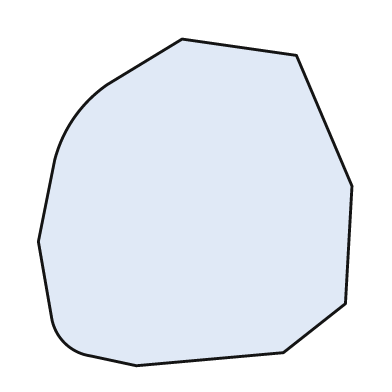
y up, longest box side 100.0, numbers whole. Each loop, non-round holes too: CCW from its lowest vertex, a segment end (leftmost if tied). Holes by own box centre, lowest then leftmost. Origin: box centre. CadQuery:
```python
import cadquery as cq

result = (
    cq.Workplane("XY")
    .moveTo(-18.0, -50.0)
    .lineTo(27.0, -46.0)
    .lineTo(46.0, -31.0)
    .lineTo(48.0, 5.0)
    .lineTo(31.0, 45.0)
    .lineTo(-4.0, 50.0)
    .lineTo(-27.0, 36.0)
    .threePointArc((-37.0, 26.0), (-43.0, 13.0))
    .lineTo(-48.0, -12.0)
    .lineTo(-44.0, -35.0)
    .threePointArc((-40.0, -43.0), (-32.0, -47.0))
    .close()
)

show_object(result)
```